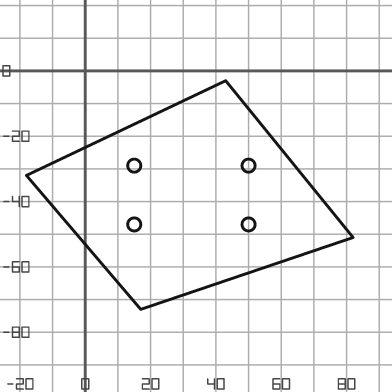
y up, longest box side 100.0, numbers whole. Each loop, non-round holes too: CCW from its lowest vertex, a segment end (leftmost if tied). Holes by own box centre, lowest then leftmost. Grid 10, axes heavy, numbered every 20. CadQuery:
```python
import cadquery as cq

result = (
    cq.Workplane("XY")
    .moveTo(17.0, -73.0)
    .lineTo(82.0, -51.0)
    .lineTo(43.0, -3.0)
    .lineTo(-18.0, -32.0)
    .close()
    .moveTo(15.0, -47.0)
    .circle(2.0)
    .moveTo(50.0, -47.0)
    .circle(2.0)
    .moveTo(15.0, -29.0)
    .circle(2.0)
    .moveTo(50.0, -29.0)
    .circle(2.0)
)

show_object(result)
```